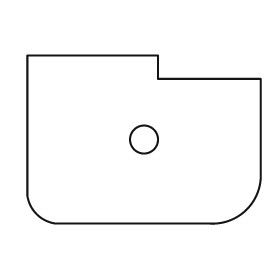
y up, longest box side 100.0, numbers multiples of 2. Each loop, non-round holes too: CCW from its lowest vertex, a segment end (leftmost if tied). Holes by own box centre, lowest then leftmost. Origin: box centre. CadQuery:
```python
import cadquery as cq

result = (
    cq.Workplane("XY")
    .moveTo(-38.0, -36.0)
    .lineTo(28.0, -36.0)
    .threePointArc((44.0, -30.0), (50.0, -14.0))
    .lineTo(50.0, 26.0)
    .lineTo(6.0, 26.0)
    .lineTo(6.0, 36.0)
    .lineTo(-50.0, 36.0)
    .lineTo(-50.0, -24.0)
    .threePointArc((-46.0, -32.0), (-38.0, -36.0))
    .close()
    .moveTo(0.0, 0.0)
    .circle(6.0)
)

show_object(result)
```